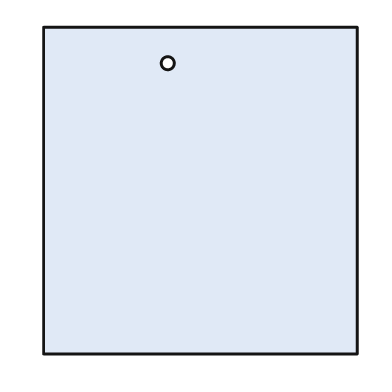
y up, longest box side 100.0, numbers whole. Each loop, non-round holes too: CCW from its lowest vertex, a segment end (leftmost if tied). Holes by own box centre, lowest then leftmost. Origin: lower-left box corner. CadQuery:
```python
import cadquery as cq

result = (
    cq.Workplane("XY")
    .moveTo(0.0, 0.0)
    .lineTo(96.0, 0.0)
    .lineTo(96.0, 100.0)
    .lineTo(0.0, 100.0)
    .close()
    .moveTo(38.0, 89.0)
    .circle(2.0)
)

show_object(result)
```